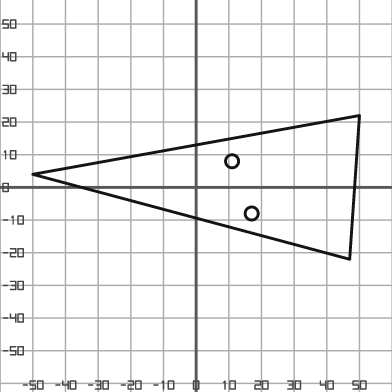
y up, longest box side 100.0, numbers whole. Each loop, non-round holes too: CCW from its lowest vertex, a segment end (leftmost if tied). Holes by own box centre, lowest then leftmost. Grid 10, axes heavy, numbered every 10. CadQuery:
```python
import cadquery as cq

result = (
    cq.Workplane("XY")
    .moveTo(47.0, -22.0)
    .lineTo(50.0, 22.0)
    .lineTo(-50.0, 4.0)
    .close()
    .moveTo(17.0, -8.0)
    .circle(2.0)
    .moveTo(11.0, 8.0)
    .circle(2.0)
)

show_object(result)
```